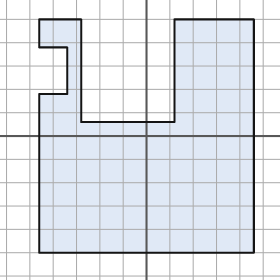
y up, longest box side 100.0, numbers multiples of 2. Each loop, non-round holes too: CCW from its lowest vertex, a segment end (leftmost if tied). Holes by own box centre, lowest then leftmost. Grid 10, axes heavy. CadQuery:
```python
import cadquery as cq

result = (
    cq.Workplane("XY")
    .moveTo(-46.0, -50.0)
    .lineTo(46.0, -50.0)
    .lineTo(46.0, 50.0)
    .lineTo(12.0, 50.0)
    .lineTo(12.0, 6.0)
    .lineTo(-28.0, 6.0)
    .lineTo(-28.0, 50.0)
    .lineTo(-46.0, 50.0)
    .lineTo(-46.0, 38.0)
    .lineTo(-34.0, 38.0)
    .lineTo(-34.0, 18.0)
    .lineTo(-46.0, 18.0)
    .close()
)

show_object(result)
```